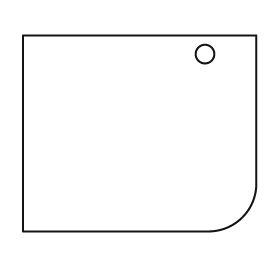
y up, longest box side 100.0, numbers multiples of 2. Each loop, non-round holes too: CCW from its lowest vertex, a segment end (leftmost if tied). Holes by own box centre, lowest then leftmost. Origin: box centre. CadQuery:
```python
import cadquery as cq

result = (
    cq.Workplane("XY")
    .moveTo(-50.0, -42.0)
    .lineTo(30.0, -42.0)
    .threePointArc((44.0, -36.0), (50.0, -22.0))
    .lineTo(50.0, 42.0)
    .lineTo(-50.0, 42.0)
    .close()
    .moveTo(28.0, 34.0)
    .circle(4.0)
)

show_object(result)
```